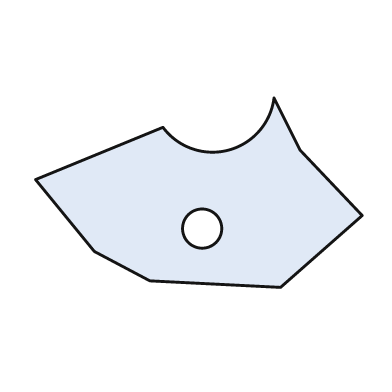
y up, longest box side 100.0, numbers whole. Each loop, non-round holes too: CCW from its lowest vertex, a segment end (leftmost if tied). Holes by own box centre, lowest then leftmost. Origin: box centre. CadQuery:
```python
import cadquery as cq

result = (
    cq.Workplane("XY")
    .moveTo(25.0, -29.0)
    .lineTo(50.0, -7.0)
    .lineTo(31.0, 13.0)
    .lineTo(23.0, 29.0)
    .threePointArc((9.0, 13.0), (-11.0, 20.0))
    .lineTo(-50.0, 4.0)
    .lineTo(-32.0, -18.0)
    .lineTo(-15.0, -27.0)
    .close()
    .moveTo(1.0, -11.0)
    .circle(6.0)
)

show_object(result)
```